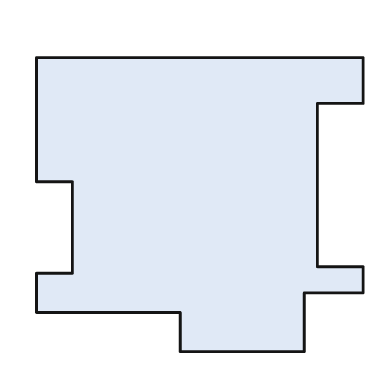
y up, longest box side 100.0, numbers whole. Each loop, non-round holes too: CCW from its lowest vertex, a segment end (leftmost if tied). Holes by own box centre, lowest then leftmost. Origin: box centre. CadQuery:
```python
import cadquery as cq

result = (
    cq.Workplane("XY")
    .moveTo(-6.0, -45.0)
    .lineTo(32.0, -45.0)
    .lineTo(32.0, -27.0)
    .lineTo(50.0, -27.0)
    .lineTo(50.0, -19.0)
    .lineTo(36.0, -19.0)
    .lineTo(36.0, 31.0)
    .lineTo(50.0, 31.0)
    .lineTo(50.0, 45.0)
    .lineTo(-50.0, 45.0)
    .lineTo(-50.0, 7.0)
    .lineTo(-39.0, 7.0)
    .lineTo(-39.0, -21.0)
    .lineTo(-50.0, -21.0)
    .lineTo(-50.0, -33.0)
    .lineTo(-6.0, -33.0)
    .close()
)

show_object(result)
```